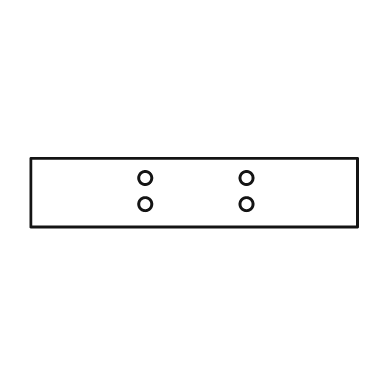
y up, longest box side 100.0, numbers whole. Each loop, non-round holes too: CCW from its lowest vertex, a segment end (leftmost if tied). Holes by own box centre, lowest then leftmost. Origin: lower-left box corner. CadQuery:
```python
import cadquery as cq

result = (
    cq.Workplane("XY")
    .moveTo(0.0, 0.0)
    .lineTo(100.0, 0.0)
    .lineTo(100.0, 21.0)
    .lineTo(0.0, 21.0)
    .close()
    .moveTo(35.0, 7.0)
    .circle(2.0)
    .moveTo(66.0, 7.0)
    .circle(2.0)
    .moveTo(35.0, 15.0)
    .circle(2.0)
    .moveTo(66.0, 15.0)
    .circle(2.0)
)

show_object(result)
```